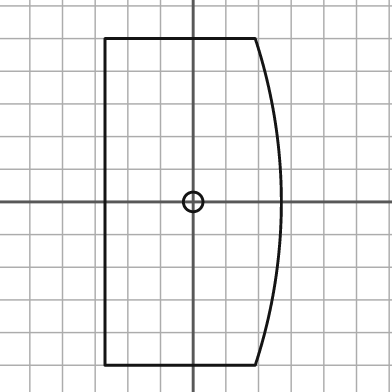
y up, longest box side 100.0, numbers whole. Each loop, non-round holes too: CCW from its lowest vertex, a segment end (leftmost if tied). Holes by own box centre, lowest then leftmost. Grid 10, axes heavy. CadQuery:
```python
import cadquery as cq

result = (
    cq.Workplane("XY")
    .moveTo(-27.0, -50.0)
    .lineTo(19.0, -50.0)
    .threePointArc((27.0, 0.0), (19.0, 50.0))
    .lineTo(-27.0, 50.0)
    .close()
    .moveTo(0.0, 0.0)
    .circle(3.0)
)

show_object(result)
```